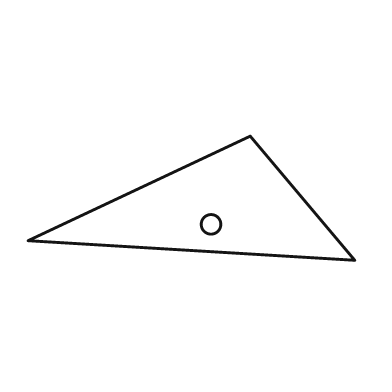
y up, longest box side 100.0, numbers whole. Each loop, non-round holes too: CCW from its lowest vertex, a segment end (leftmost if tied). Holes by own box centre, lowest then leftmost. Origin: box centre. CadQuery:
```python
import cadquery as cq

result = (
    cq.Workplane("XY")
    .moveTo(50.0, -19.0)
    .lineTo(18.0, 19.0)
    .lineTo(-50.0, -13.0)
    .close()
    .moveTo(6.0, -8.0)
    .circle(3.0)
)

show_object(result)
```